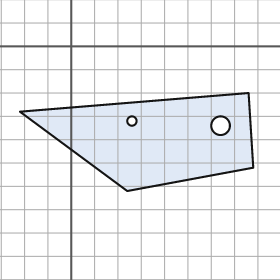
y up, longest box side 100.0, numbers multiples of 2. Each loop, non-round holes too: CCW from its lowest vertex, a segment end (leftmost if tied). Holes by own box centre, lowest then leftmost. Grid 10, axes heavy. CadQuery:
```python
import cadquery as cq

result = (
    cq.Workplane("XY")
    .moveTo(24.0, -62.0)
    .lineTo(78.0, -52.0)
    .lineTo(76.0, -20.0)
    .lineTo(-22.0, -28.0)
    .close()
    .moveTo(64.0, -34.0)
    .circle(4.0)
    .moveTo(26.0, -32.0)
    .circle(2.0)
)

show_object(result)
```